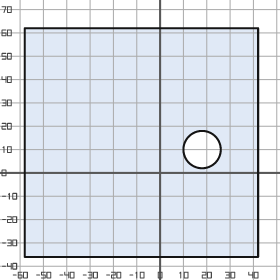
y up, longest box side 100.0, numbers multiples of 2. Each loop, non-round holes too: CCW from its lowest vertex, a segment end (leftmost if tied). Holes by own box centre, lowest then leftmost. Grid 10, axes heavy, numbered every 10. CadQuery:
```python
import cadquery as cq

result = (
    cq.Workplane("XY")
    .moveTo(-58.0, -36.0)
    .lineTo(42.0, -36.0)
    .lineTo(42.0, 62.0)
    .lineTo(-58.0, 62.0)
    .close()
    .moveTo(18.0, 10.0)
    .circle(8.0)
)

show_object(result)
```